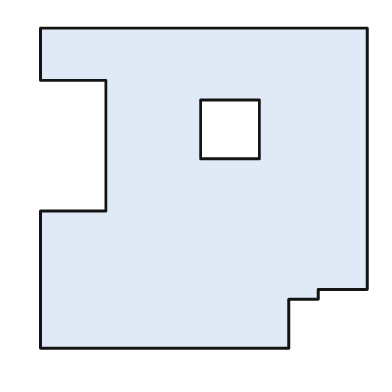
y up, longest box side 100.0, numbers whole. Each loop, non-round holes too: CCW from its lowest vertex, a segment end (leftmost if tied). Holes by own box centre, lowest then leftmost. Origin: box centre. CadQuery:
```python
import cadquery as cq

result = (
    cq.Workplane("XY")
    .moveTo(-50.0, -49.0)
    .lineTo(26.0, -49.0)
    .lineTo(26.0, -34.0)
    .lineTo(35.0, -34.0)
    .lineTo(35.0, -31.0)
    .lineTo(50.0, -31.0)
    .lineTo(50.0, 49.0)
    .lineTo(-50.0, 49.0)
    .lineTo(-50.0, 33.0)
    .lineTo(-30.0, 33.0)
    .lineTo(-30.0, -7.0)
    .lineTo(-50.0, -7.0)
    .close()
    .moveTo(-1.0, 9.0)
    .lineTo(17.0, 9.0)
    .lineTo(17.0, 27.0)
    .lineTo(-1.0, 27.0)
    .close()
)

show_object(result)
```